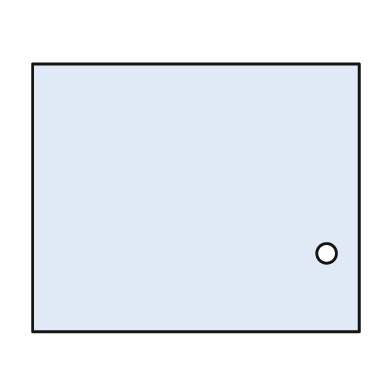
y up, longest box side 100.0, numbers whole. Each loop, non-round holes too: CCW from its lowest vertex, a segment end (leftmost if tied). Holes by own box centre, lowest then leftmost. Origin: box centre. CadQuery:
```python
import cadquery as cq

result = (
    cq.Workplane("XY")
    .moveTo(-50.0, -41.0)
    .lineTo(50.0, -41.0)
    .lineTo(50.0, 41.0)
    .lineTo(-50.0, 41.0)
    .close()
    .moveTo(40.0, -17.0)
    .circle(3.0)
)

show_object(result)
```